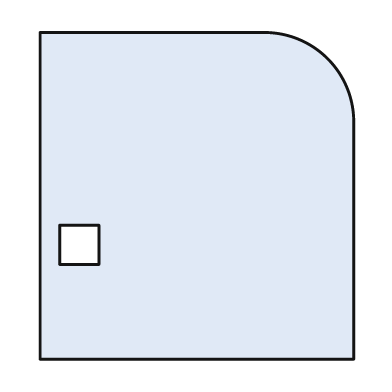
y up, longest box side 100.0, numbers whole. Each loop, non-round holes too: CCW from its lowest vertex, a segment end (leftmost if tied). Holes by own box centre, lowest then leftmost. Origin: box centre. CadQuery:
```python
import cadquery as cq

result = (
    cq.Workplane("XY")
    .moveTo(-48.0, -50.0)
    .lineTo(48.0, -50.0)
    .lineTo(48.0, 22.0)
    .threePointArc((40.0, 42.0), (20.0, 50.0))
    .lineTo(-48.0, 50.0)
    .close()
    .moveTo(-42.0, -21.0)
    .lineTo(-30.0, -21.0)
    .lineTo(-30.0, -9.0)
    .lineTo(-42.0, -9.0)
    .close()
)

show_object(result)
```